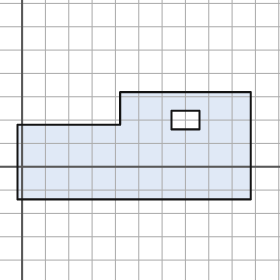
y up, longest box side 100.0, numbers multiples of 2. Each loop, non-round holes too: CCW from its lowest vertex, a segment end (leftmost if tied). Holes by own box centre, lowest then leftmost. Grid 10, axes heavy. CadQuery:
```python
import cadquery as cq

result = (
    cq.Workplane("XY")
    .moveTo(-2.0, -14.0)
    .lineTo(98.0, -14.0)
    .lineTo(98.0, 32.0)
    .lineTo(42.0, 32.0)
    .lineTo(42.0, 18.0)
    .lineTo(-2.0, 18.0)
    .close()
    .moveTo(64.0, 16.0)
    .lineTo(76.0, 16.0)
    .lineTo(76.0, 24.0)
    .lineTo(64.0, 24.0)
    .close()
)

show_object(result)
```